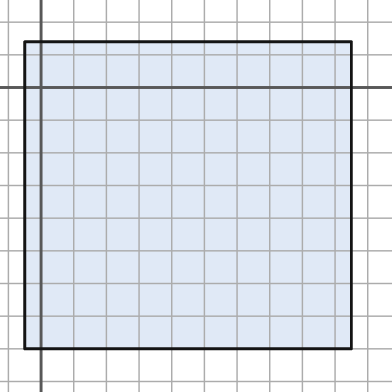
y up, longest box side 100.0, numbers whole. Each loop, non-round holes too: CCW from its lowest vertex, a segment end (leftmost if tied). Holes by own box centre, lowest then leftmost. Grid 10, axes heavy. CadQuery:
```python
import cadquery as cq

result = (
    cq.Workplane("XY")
    .moveTo(-5.0, -80.0)
    .lineTo(95.0, -80.0)
    .lineTo(95.0, 14.0)
    .lineTo(-5.0, 14.0)
    .close()
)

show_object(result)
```